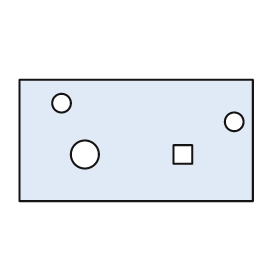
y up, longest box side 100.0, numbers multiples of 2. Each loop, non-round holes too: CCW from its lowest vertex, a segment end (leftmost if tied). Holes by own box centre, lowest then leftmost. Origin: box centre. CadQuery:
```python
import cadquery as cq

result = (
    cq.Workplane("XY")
    .moveTo(-50.0, -26.0)
    .lineTo(50.0, -26.0)
    .lineTo(50.0, 26.0)
    .lineTo(-50.0, 26.0)
    .close()
    .moveTo(-22.0, -6.0)
    .circle(6.0)
    .moveTo(16.0, -10.0)
    .lineTo(24.0, -10.0)
    .lineTo(24.0, -2.0)
    .lineTo(16.0, -2.0)
    .close()
    .moveTo(42.0, 8.0)
    .circle(4.0)
    .moveTo(-32.0, 16.0)
    .circle(4.0)
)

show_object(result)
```